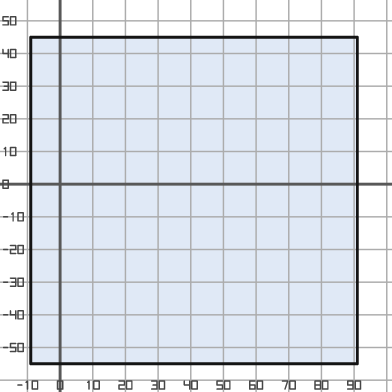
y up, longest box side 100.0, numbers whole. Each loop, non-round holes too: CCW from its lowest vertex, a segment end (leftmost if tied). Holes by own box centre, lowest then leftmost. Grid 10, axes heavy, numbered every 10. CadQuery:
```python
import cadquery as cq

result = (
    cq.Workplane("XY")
    .moveTo(-9.0, -55.0)
    .lineTo(91.0, -55.0)
    .lineTo(91.0, 45.0)
    .lineTo(-9.0, 45.0)
    .close()
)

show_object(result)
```